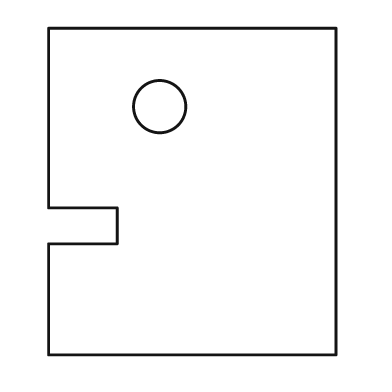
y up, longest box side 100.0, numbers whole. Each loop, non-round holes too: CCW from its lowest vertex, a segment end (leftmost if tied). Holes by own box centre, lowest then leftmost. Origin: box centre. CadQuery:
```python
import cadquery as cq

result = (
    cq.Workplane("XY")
    .moveTo(-44.0, -50.0)
    .lineTo(44.0, -50.0)
    .lineTo(44.0, 50.0)
    .lineTo(-44.0, 50.0)
    .lineTo(-44.0, -5.0)
    .lineTo(-23.0, -5.0)
    .lineTo(-23.0, -16.0)
    .lineTo(-44.0, -16.0)
    .close()
    .moveTo(-10.0, 26.0)
    .circle(8.0)
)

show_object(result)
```